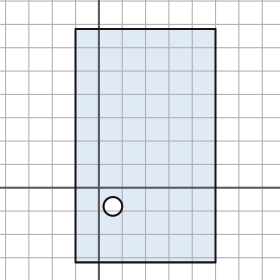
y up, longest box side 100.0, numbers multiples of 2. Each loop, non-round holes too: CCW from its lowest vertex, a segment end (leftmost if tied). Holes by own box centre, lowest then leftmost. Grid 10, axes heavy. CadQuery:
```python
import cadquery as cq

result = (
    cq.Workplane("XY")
    .moveTo(-10.0, -32.0)
    .lineTo(50.0, -32.0)
    .lineTo(50.0, 68.0)
    .lineTo(-10.0, 68.0)
    .close()
    .moveTo(6.0, -8.0)
    .circle(4.0)
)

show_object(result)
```